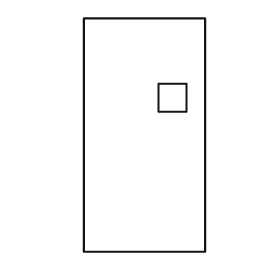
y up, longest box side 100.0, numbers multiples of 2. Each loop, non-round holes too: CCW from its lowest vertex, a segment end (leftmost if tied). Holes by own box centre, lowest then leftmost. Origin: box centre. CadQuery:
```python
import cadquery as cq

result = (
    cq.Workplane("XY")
    .moveTo(-26.0, -50.0)
    .lineTo(26.0, -50.0)
    .lineTo(26.0, 50.0)
    .lineTo(-26.0, 50.0)
    .close()
    .moveTo(6.0, 10.0)
    .lineTo(18.0, 10.0)
    .lineTo(18.0, 22.0)
    .lineTo(6.0, 22.0)
    .close()
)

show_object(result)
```